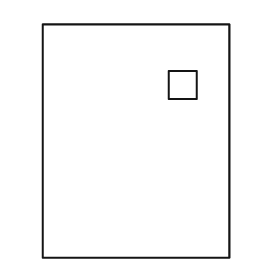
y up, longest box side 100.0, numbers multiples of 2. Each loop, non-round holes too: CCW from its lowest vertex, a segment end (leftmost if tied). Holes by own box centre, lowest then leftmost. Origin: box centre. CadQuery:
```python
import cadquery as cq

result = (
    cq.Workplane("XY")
    .moveTo(-40.0, -50.0)
    .lineTo(40.0, -50.0)
    .lineTo(40.0, 50.0)
    .lineTo(-40.0, 50.0)
    .close()
    .moveTo(14.0, 18.0)
    .lineTo(26.0, 18.0)
    .lineTo(26.0, 30.0)
    .lineTo(14.0, 30.0)
    .close()
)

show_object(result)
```